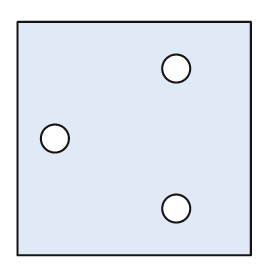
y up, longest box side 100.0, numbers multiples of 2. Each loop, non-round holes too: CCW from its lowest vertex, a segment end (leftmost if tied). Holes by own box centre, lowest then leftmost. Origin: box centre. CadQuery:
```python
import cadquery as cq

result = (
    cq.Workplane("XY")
    .moveTo(-50.0, -50.0)
    .lineTo(50.0, -50.0)
    .lineTo(50.0, 50.0)
    .lineTo(-50.0, 50.0)
    .close()
    .moveTo(18.0, -30.0)
    .circle(6.0)
    .moveTo(-34.0, 0.0)
    .circle(6.0)
    .moveTo(18.0, 30.0)
    .circle(6.0)
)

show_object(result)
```